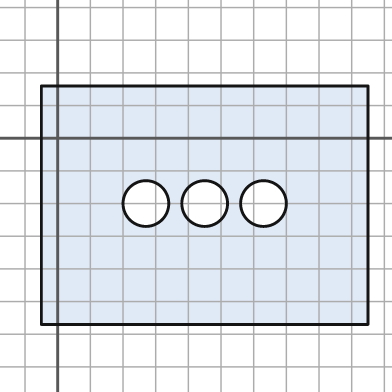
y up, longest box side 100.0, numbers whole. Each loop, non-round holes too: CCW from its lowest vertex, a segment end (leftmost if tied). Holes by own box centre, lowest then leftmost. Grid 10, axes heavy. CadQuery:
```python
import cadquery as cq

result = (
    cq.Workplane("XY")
    .moveTo(-5.0, -57.0)
    .lineTo(95.0, -57.0)
    .lineTo(95.0, 16.0)
    .lineTo(-5.0, 16.0)
    .close()
    .moveTo(27.0, -20.0)
    .circle(7.0)
    .moveTo(45.0, -20.0)
    .circle(7.0)
    .moveTo(63.0, -20.0)
    .circle(7.0)
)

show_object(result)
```